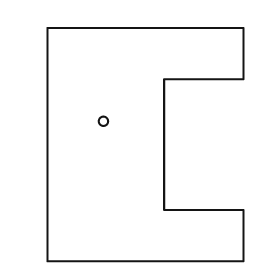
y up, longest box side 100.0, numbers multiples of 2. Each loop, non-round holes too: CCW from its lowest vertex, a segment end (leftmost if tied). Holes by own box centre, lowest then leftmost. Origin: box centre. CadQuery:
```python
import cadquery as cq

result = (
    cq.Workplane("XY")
    .moveTo(-42.0, -50.0)
    .lineTo(42.0, -50.0)
    .lineTo(42.0, -28.0)
    .lineTo(8.0, -28.0)
    .lineTo(8.0, 28.0)
    .lineTo(42.0, 28.0)
    .lineTo(42.0, 50.0)
    .lineTo(-42.0, 50.0)
    .close()
    .moveTo(-18.0, 10.0)
    .circle(2.0)
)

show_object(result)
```